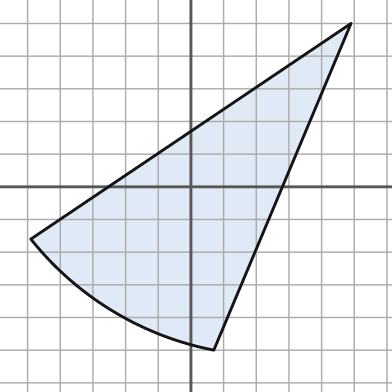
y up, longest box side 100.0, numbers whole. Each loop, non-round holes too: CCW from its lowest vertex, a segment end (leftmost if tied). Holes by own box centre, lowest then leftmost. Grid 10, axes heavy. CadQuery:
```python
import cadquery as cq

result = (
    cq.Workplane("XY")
    .moveTo(7.0, -50.0)
    .lineTo(49.0, 50.0)
    .lineTo(-49.0, -16.0)
    .threePointArc((-24.0, -38.0), (7.0, -50.0))
    .close()
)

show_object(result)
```